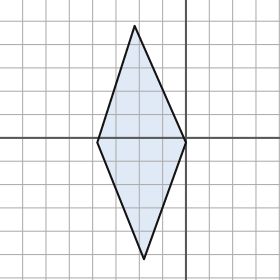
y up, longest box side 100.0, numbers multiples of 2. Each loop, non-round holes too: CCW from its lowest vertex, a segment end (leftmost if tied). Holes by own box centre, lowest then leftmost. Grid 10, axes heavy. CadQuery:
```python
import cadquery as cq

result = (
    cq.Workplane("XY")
    .moveTo(-18.0, -52.0)
    .lineTo(0.0, -2.0)
    .lineTo(-22.0, 48.0)
    .lineTo(-38.0, -2.0)
    .close()
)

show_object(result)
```